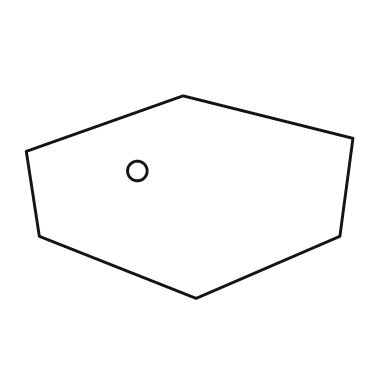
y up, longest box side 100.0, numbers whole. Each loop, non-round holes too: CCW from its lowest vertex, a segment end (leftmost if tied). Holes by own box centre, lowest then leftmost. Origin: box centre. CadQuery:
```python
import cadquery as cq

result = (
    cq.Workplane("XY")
    .moveTo(2.0, -31.0)
    .lineTo(46.0, -12.0)
    .lineTo(50.0, 18.0)
    .lineTo(-2.0, 31.0)
    .lineTo(-50.0, 14.0)
    .lineTo(-46.0, -12.0)
    .close()
    .moveTo(-16.0, 8.0)
    .circle(3.0)
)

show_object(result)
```